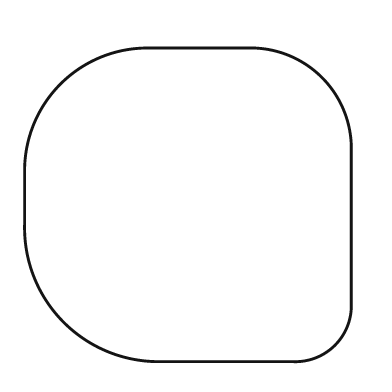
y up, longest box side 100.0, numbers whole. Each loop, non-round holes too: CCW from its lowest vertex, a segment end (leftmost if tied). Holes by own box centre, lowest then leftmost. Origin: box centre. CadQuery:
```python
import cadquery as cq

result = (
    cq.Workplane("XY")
    .moveTo(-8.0, -48.0)
    .lineTo(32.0, -48.0)
    .threePointArc((45.0, -43.0), (50.0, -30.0))
    .lineTo(50.0, 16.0)
    .threePointArc((41.0, 39.0), (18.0, 48.0))
    .lineTo(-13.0, 48.0)
    .threePointArc((-39.0, 37.0), (-50.0, 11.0))
    .lineTo(-50.0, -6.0)
    .threePointArc((-38.0, -36.0), (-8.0, -48.0))
    .close()
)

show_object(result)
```